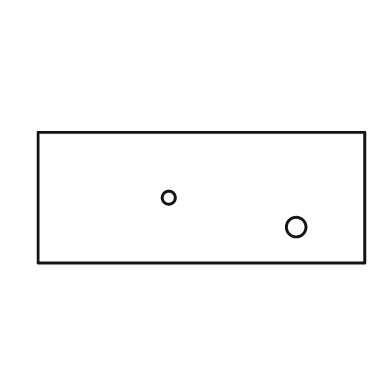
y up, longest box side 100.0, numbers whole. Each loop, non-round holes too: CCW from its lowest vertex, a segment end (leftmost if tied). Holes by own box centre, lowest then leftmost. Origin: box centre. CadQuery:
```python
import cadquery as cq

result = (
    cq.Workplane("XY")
    .moveTo(-50.0, -20.0)
    .lineTo(50.0, -20.0)
    .lineTo(50.0, 20.0)
    .lineTo(-50.0, 20.0)
    .close()
    .moveTo(29.0, -9.0)
    .circle(3.0)
    .moveTo(-10.0, 0.0)
    .circle(2.0)
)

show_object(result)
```